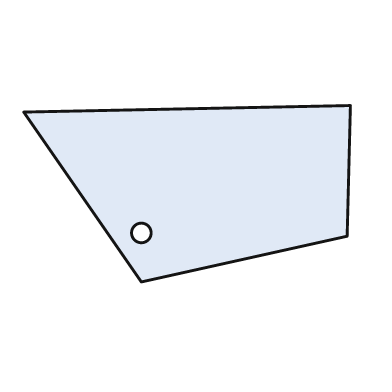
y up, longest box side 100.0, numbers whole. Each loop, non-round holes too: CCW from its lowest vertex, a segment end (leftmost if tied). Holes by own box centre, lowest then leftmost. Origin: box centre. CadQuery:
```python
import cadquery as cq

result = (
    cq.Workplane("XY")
    .moveTo(-14.0, -27.0)
    .lineTo(49.0, -13.0)
    .lineTo(50.0, 27.0)
    .lineTo(-50.0, 25.0)
    .close()
    .moveTo(-14.0, -12.0)
    .circle(3.0)
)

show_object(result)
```